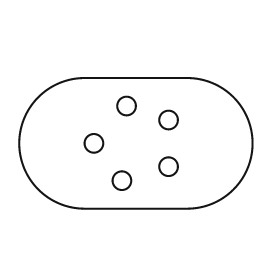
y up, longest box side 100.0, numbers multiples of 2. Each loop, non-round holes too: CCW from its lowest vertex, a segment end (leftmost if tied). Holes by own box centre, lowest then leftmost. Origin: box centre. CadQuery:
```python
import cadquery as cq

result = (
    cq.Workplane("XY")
    .moveTo(-22.0, -28.0)
    .lineTo(22.0, -28.0)
    .threePointArc((50.0, 0.0), (22.0, 28.0))
    .lineTo(-22.0, 28.0)
    .threePointArc((-50.0, 0.0), (-22.0, -28.0))
    .close()
    .moveTo(-6.0, -16.0)
    .circle(4.0)
    .moveTo(14.0, -10.0)
    .circle(4.0)
    .moveTo(-18.0, 0.0)
    .circle(4.0)
    .moveTo(14.0, 10.0)
    .circle(4.0)
    .moveTo(-4.0, 16.0)
    .circle(4.0)
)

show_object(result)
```